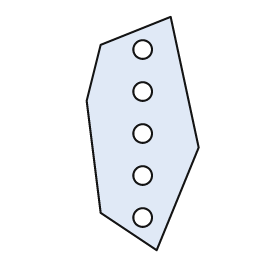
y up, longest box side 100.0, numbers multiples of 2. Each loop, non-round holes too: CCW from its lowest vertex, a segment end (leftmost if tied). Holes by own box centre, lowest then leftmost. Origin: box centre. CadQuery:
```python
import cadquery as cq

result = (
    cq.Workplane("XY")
    .moveTo(6.0, -50.0)
    .lineTo(24.0, -6.0)
    .lineTo(12.0, 50.0)
    .lineTo(-18.0, 38.0)
    .lineTo(-24.0, 14.0)
    .lineTo(-18.0, -34.0)
    .close()
    .moveTo(0.0, -36.0)
    .circle(4.0)
    .moveTo(0.0, -18.0)
    .circle(4.0)
    .moveTo(0.0, 0.0)
    .circle(4.0)
    .moveTo(0.0, 18.0)
    .circle(4.0)
    .moveTo(0.0, 36.0)
    .circle(4.0)
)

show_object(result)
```